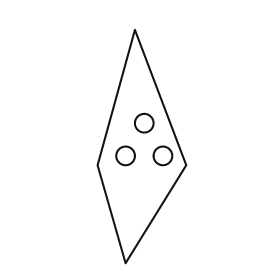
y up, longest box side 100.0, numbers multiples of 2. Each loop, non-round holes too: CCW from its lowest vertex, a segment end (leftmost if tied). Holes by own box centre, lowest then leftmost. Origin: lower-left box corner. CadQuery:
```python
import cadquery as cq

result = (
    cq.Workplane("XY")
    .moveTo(12.0, 0.0)
    .lineTo(38.0, 42.0)
    .lineTo(16.0, 100.0)
    .lineTo(0.0, 42.0)
    .close()
    .moveTo(12.0, 46.0)
    .circle(4.0)
    .moveTo(28.0, 46.0)
    .circle(4.0)
    .moveTo(20.0, 60.0)
    .circle(4.0)
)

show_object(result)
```